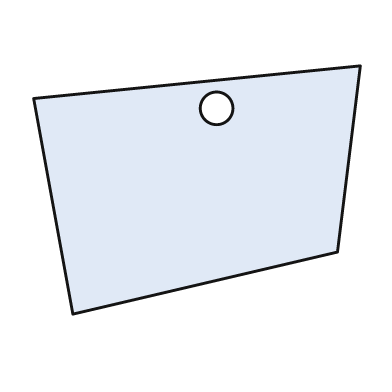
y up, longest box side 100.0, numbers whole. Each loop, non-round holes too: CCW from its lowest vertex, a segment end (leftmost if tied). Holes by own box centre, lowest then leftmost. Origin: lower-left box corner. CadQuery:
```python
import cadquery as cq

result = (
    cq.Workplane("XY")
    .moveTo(12.0, 0.0)
    .lineTo(93.0, 19.0)
    .lineTo(100.0, 76.0)
    .lineTo(0.0, 66.0)
    .close()
    .moveTo(56.0, 63.0)
    .circle(5.0)
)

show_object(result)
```